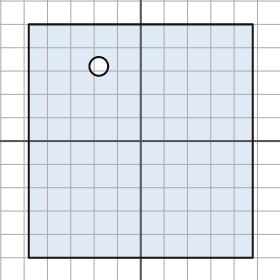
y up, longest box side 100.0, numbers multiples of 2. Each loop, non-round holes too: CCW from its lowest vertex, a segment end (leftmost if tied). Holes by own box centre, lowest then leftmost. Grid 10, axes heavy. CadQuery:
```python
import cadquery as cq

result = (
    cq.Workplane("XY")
    .moveTo(-48.0, -50.0)
    .lineTo(48.0, -50.0)
    .lineTo(48.0, 50.0)
    .lineTo(-48.0, 50.0)
    .close()
    .moveTo(-18.0, 32.0)
    .circle(4.0)
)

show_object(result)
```